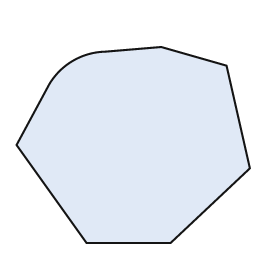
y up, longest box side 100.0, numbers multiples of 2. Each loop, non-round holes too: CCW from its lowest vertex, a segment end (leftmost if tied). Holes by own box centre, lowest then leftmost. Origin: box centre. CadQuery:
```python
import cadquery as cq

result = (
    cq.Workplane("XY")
    .moveTo(-20.0, -42.0)
    .lineTo(16.0, -42.0)
    .lineTo(50.0, -10.0)
    .lineTo(40.0, 34.0)
    .lineTo(12.0, 42.0)
    .lineTo(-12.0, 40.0)
    .threePointArc((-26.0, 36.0), (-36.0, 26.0))
    .lineTo(-50.0, 0.0)
    .close()
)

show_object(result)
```